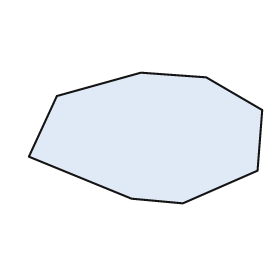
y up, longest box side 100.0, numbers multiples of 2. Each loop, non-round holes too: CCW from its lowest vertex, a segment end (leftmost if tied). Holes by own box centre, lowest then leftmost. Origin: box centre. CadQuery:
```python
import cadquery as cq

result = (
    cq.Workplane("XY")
    .moveTo(16.0, -28.0)
    .lineTo(48.0, -14.0)
    .lineTo(50.0, 12.0)
    .lineTo(26.0, 26.0)
    .lineTo(-2.0, 28.0)
    .lineTo(-38.0, 18.0)
    .lineTo(-50.0, -8.0)
    .lineTo(-6.0, -26.0)
    .close()
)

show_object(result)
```